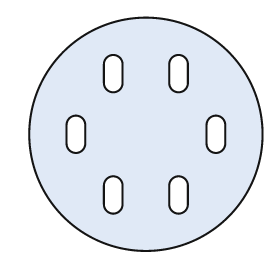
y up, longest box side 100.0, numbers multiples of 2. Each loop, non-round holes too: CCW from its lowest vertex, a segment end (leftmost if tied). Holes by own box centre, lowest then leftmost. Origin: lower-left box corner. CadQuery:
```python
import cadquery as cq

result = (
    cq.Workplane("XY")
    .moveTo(50.0, 50.0)
    .circle(50.0)
    .moveTo(32.0, 20.0)
    .threePointArc((36.0, 16.0), (40.0, 20.0))
    .lineTo(40.0, 28.0)
    .threePointArc((36.0, 32.0), (32.0, 28.0))
    .close()
    .moveTo(60.0, 20.0)
    .threePointArc((64.0, 16.0), (68.0, 20.0))
    .lineTo(68.0, 28.0)
    .threePointArc((64.0, 32.0), (60.0, 28.0))
    .close()
    .moveTo(16.0, 46.0)
    .threePointArc((20.0, 42.0), (24.0, 46.0))
    .lineTo(24.0, 54.0)
    .threePointArc((20.0, 58.0), (16.0, 54.0))
    .close()
    .moveTo(76.0, 46.0)
    .threePointArc((80.0, 42.0), (84.0, 46.0))
    .lineTo(84.0, 54.0)
    .threePointArc((80.0, 58.0), (76.0, 54.0))
    .close()
    .moveTo(32.0, 72.0)
    .threePointArc((36.0, 68.0), (40.0, 72.0))
    .lineTo(40.0, 80.0)
    .threePointArc((36.0, 84.0), (32.0, 80.0))
    .close()
    .moveTo(60.0, 72.0)
    .threePointArc((64.0, 68.0), (68.0, 72.0))
    .lineTo(68.0, 80.0)
    .threePointArc((64.0, 84.0), (60.0, 80.0))
    .close()
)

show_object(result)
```